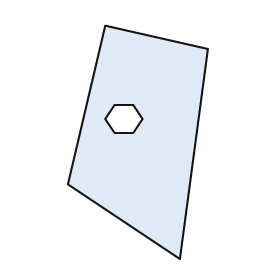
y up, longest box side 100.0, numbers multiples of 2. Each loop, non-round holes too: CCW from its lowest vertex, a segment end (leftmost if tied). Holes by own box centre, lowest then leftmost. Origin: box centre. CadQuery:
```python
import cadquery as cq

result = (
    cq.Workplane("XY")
    .moveTo(18.0, -50.0)
    .lineTo(30.0, 40.0)
    .lineTo(-14.0, 50.0)
    .lineTo(-30.0, -18.0)
    .close()
    .moveTo(-10.0, 4.0)
    .lineTo(-2.0, 4.0)
    .lineTo(2.0, 10.0)
    .lineTo(-2.0, 16.0)
    .lineTo(-10.0, 16.0)
    .lineTo(-14.0, 10.0)
    .close()
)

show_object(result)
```